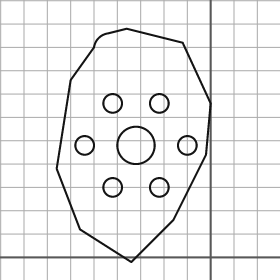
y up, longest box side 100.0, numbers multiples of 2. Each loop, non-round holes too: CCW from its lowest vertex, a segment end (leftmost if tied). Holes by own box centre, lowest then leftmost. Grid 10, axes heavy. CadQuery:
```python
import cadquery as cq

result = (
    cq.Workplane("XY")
    .moveTo(-34.0, -2.0)
    .lineTo(-16.0, 16.0)
    .lineTo(-2.0, 44.0)
    .lineTo(0.0, 66.0)
    .lineTo(-12.0, 92.0)
    .lineTo(-36.0, 98.0)
    .lineTo(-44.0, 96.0)
    .threePointArc((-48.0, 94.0), (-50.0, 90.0))
    .lineTo(-60.0, 76.0)
    .lineTo(-66.0, 38.0)
    .lineTo(-56.0, 12.0)
    .close()
    .moveTo(-42.0, 30.0)
    .circle(4.0)
    .moveTo(-22.0, 30.0)
    .circle(4.0)
    .moveTo(-54.0, 48.0)
    .circle(4.0)
    .moveTo(-32.0, 48.0)
    .circle(8.0)
    .moveTo(-10.0, 48.0)
    .circle(4.0)
    .moveTo(-42.0, 66.0)
    .circle(4.0)
    .moveTo(-22.0, 66.0)
    .circle(4.0)
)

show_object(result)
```